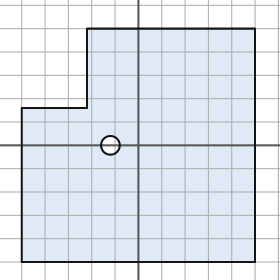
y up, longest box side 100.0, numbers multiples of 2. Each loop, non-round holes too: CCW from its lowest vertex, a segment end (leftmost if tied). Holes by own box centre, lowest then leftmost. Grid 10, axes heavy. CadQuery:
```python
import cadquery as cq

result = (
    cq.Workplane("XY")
    .moveTo(-50.0, -50.0)
    .lineTo(50.0, -50.0)
    .lineTo(50.0, 50.0)
    .lineTo(-22.0, 50.0)
    .lineTo(-22.0, 16.0)
    .lineTo(-50.0, 16.0)
    .close()
    .moveTo(-12.0, 0.0)
    .circle(4.0)
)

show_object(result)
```